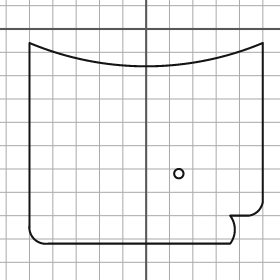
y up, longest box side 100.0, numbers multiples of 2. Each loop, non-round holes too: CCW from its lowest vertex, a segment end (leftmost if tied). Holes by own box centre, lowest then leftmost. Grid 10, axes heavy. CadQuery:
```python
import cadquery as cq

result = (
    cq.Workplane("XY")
    .moveTo(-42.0, -92.0)
    .lineTo(36.0, -92.0)
    .threePointArc((38.0, -86.0), (36.0, -80.0))
    .lineTo(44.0, -80.0)
    .threePointArc((48.0, -78.0), (50.0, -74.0))
    .lineTo(50.0, -6.0)
    .threePointArc((0.0, -16.0), (-50.0, -6.0))
    .lineTo(-50.0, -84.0)
    .threePointArc((-48.0, -90.0), (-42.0, -92.0))
    .close()
    .moveTo(14.0, -62.0)
    .circle(2.0)
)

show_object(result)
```